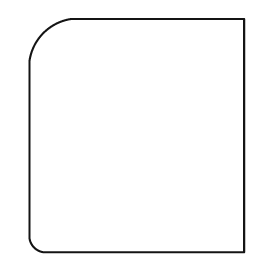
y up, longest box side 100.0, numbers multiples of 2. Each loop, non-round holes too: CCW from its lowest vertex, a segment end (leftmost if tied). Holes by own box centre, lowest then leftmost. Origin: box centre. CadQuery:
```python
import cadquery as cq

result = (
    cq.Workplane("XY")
    .moveTo(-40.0, -50.0)
    .lineTo(46.0, -50.0)
    .lineTo(46.0, 50.0)
    .lineTo(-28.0, 50.0)
    .threePointArc((-40.0, 44.0), (-46.0, 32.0))
    .lineTo(-46.0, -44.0)
    .threePointArc((-44.0, -48.0), (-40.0, -50.0))
    .close()
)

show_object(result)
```